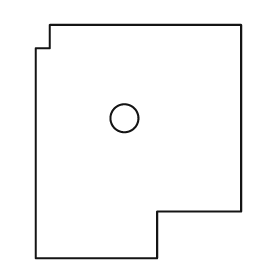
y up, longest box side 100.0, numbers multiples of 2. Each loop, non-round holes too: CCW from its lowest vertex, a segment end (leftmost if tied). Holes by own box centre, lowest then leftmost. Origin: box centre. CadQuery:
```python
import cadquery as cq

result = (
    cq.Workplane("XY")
    .moveTo(-44.0, -50.0)
    .lineTo(8.0, -50.0)
    .lineTo(8.0, -30.0)
    .lineTo(44.0, -30.0)
    .lineTo(44.0, 50.0)
    .lineTo(-38.0, 50.0)
    .lineTo(-38.0, 40.0)
    .lineTo(-44.0, 40.0)
    .close()
    .moveTo(-6.0, 10.0)
    .circle(6.0)
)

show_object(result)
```